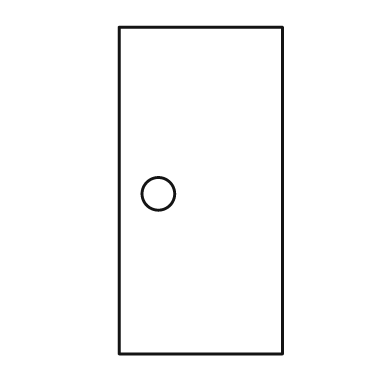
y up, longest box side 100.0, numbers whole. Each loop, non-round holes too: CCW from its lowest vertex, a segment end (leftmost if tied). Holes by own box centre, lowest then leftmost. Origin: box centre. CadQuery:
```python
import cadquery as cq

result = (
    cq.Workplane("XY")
    .moveTo(-25.0, -50.0)
    .lineTo(25.0, -50.0)
    .lineTo(25.0, 50.0)
    .lineTo(-25.0, 50.0)
    .close()
    .moveTo(-13.0, -1.0)
    .circle(5.0)
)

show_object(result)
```